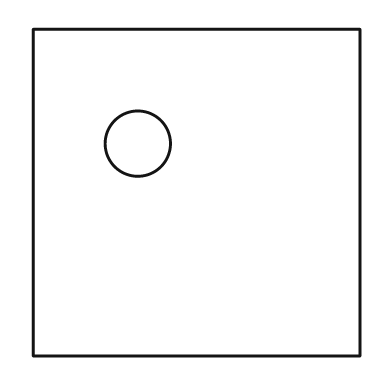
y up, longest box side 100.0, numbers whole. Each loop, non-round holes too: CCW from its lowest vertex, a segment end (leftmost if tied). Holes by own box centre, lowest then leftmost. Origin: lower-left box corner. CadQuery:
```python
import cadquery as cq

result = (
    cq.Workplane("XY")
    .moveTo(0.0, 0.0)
    .lineTo(100.0, 0.0)
    .lineTo(100.0, 100.0)
    .lineTo(0.0, 100.0)
    .close()
    .moveTo(32.0, 65.0)
    .circle(10.0)
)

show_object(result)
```